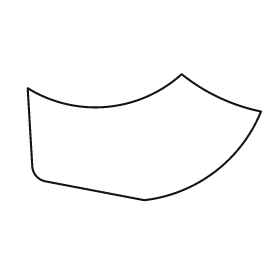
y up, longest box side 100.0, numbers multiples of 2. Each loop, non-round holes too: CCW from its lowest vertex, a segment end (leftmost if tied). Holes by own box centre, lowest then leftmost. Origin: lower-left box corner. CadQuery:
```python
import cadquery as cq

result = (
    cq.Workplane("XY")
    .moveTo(50.0, 0.0)
    .threePointArc((80.0, 12.0), (100.0, 38.0))
    .threePointArc((82.0, 44.0), (66.0, 54.0))
    .threePointArc((34.0, 40.0), (0.0, 48.0))
    .lineTo(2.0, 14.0)
    .threePointArc((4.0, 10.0), (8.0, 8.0))
    .close()
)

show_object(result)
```